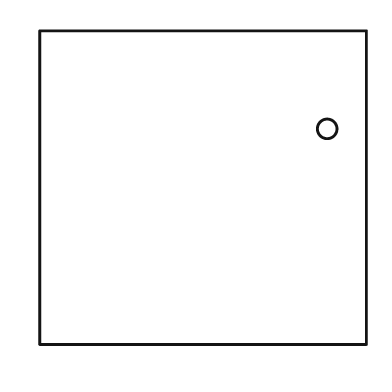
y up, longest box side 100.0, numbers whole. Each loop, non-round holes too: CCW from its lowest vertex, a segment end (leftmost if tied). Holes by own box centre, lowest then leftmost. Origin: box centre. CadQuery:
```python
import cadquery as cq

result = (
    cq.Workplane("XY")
    .moveTo(-50.0, -48.0)
    .lineTo(50.0, -48.0)
    .lineTo(50.0, 48.0)
    .lineTo(-50.0, 48.0)
    .close()
    .moveTo(38.0, 18.0)
    .circle(3.0)
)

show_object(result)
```